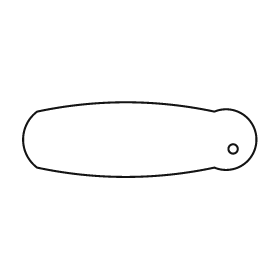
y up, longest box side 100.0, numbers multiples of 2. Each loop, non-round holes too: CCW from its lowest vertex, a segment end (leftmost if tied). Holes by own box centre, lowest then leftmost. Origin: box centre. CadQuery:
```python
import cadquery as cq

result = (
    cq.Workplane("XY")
    .moveTo(-44.0, -12.0)
    .threePointArc((-6.0, -16.0), (32.0, -12.0))
    .threePointArc((50.0, 0.0), (32.0, 12.0))
    .threePointArc((-6.0, 16.0), (-44.0, 12.0))
    .threePointArc((-50.0, 0.0), (-44.0, -12.0))
    .close()
    .moveTo(40.0, -4.0)
    .circle(2.0)
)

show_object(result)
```